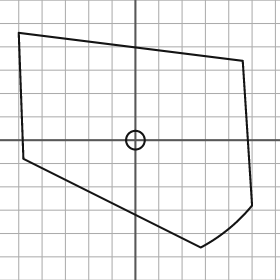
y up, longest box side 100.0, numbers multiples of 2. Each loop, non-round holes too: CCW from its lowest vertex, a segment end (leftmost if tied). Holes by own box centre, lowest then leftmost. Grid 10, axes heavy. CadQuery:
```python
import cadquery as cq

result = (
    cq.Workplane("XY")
    .moveTo(28.0, -46.0)
    .threePointArc((40.0, -38.0), (50.0, -28.0))
    .lineTo(46.0, 34.0)
    .lineTo(-50.0, 46.0)
    .lineTo(-48.0, -8.0)
    .close()
    .moveTo(0.0, 0.0)
    .circle(4.0)
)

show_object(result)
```